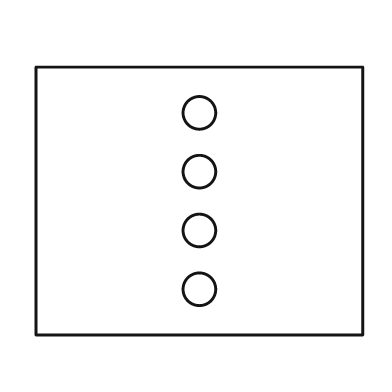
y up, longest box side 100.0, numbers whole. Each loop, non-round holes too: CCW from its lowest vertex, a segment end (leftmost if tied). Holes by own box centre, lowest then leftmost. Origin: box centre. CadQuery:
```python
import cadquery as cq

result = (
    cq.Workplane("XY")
    .moveTo(-50.0, -41.0)
    .lineTo(50.0, -41.0)
    .lineTo(50.0, 41.0)
    .lineTo(-50.0, 41.0)
    .close()
    .moveTo(0.0, -27.0)
    .circle(5.0)
    .moveTo(0.0, -9.0)
    .circle(5.0)
    .moveTo(0.0, 9.0)
    .circle(5.0)
    .moveTo(0.0, 27.0)
    .circle(5.0)
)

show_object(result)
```